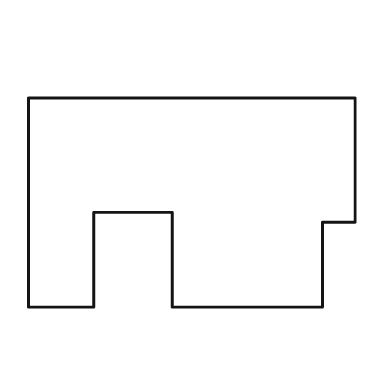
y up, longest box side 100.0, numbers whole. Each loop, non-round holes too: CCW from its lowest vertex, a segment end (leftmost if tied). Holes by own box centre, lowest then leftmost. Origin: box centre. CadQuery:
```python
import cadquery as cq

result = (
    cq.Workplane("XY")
    .moveTo(-50.0, -32.0)
    .lineTo(-30.0, -32.0)
    .lineTo(-30.0, -3.0)
    .lineTo(-6.0, -3.0)
    .lineTo(-6.0, -32.0)
    .lineTo(40.0, -32.0)
    .lineTo(40.0, -6.0)
    .lineTo(50.0, -6.0)
    .lineTo(50.0, 32.0)
    .lineTo(-50.0, 32.0)
    .close()
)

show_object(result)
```